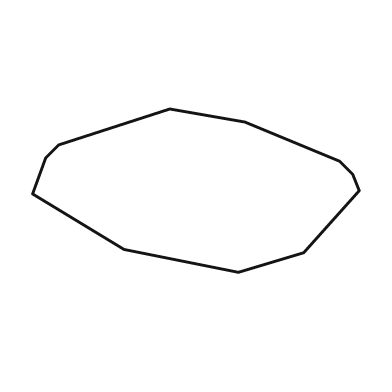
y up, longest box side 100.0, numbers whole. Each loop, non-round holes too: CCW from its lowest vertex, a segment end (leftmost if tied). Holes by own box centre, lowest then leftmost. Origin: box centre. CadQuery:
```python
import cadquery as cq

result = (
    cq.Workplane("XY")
    .moveTo(13.0, -25.0)
    .lineTo(33.0, -19.0)
    .lineTo(50.0, 0.0)
    .lineTo(48.0, 5.0)
    .lineTo(44.0, 9.0)
    .lineTo(15.0, 21.0)
    .lineTo(-8.0, 25.0)
    .lineTo(-42.0, 14.0)
    .lineTo(-46.0, 10.0)
    .lineTo(-50.0, -1.0)
    .lineTo(-22.0, -18.0)
    .close()
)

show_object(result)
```